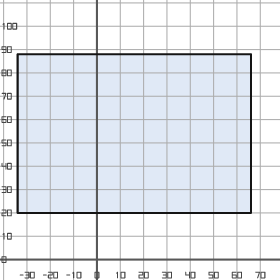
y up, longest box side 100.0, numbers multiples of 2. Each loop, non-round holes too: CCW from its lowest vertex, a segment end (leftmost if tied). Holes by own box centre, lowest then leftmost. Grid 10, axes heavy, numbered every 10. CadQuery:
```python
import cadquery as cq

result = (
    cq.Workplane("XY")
    .moveTo(-34.0, 20.0)
    .lineTo(66.0, 20.0)
    .lineTo(66.0, 88.0)
    .lineTo(-34.0, 88.0)
    .close()
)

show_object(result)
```